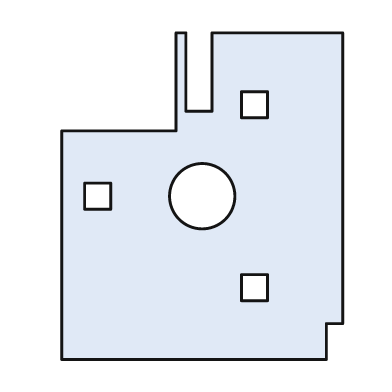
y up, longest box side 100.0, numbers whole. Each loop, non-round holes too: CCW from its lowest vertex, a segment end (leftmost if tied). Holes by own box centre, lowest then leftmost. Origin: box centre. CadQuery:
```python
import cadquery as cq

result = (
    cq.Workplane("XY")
    .moveTo(-43.0, -50.0)
    .lineTo(38.0, -50.0)
    .lineTo(38.0, -39.0)
    .lineTo(43.0, -39.0)
    .lineTo(43.0, 50.0)
    .lineTo(3.0, 50.0)
    .lineTo(3.0, 26.0)
    .lineTo(-5.0, 26.0)
    .lineTo(-5.0, 50.0)
    .lineTo(-8.0, 50.0)
    .lineTo(-8.0, 20.0)
    .lineTo(-43.0, 20.0)
    .close()
    .moveTo(12.0, -32.0)
    .lineTo(20.0, -32.0)
    .lineTo(20.0, -24.0)
    .lineTo(12.0, -24.0)
    .close()
    .moveTo(-36.0, -4.0)
    .lineTo(-28.0, -4.0)
    .lineTo(-28.0, 4.0)
    .lineTo(-36.0, 4.0)
    .close()
    .moveTo(0.0, 0.0)
    .circle(10.0)
    .moveTo(12.0, 24.0)
    .lineTo(20.0, 24.0)
    .lineTo(20.0, 32.0)
    .lineTo(12.0, 32.0)
    .close()
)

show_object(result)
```